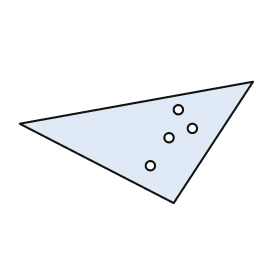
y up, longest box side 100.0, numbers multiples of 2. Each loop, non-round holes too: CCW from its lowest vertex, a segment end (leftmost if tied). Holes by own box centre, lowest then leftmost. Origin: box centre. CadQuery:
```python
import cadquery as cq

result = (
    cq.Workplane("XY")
    .moveTo(16.0, -26.0)
    .lineTo(50.0, 26.0)
    .lineTo(-50.0, 8.0)
    .close()
    .moveTo(6.0, -10.0)
    .circle(2.0)
    .moveTo(14.0, 2.0)
    .circle(2.0)
    .moveTo(24.0, 6.0)
    .circle(2.0)
    .moveTo(18.0, 14.0)
    .circle(2.0)
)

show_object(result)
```